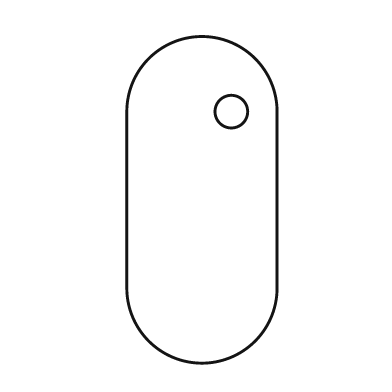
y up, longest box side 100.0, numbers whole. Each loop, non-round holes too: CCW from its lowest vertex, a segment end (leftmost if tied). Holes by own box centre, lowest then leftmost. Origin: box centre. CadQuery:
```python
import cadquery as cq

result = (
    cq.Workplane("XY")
    .moveTo(-23.0, -27.0)
    .threePointArc((0.0, -50.0), (23.0, -27.0))
    .lineTo(23.0, 27.0)
    .threePointArc((0.0, 50.0), (-23.0, 27.0))
    .close()
    .moveTo(9.0, 27.0)
    .circle(5.0)
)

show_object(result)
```